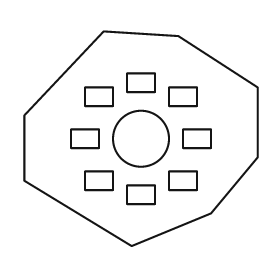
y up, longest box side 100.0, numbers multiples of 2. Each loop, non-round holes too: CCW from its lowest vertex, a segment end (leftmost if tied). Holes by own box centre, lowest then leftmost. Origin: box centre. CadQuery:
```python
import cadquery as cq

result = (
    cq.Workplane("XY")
    .moveTo(-4.0, -46.0)
    .lineTo(30.0, -32.0)
    .lineTo(50.0, -8.0)
    .lineTo(50.0, 22.0)
    .lineTo(16.0, 44.0)
    .lineTo(-16.0, 46.0)
    .lineTo(-50.0, 10.0)
    .lineTo(-50.0, -18.0)
    .close()
    .moveTo(-6.0, -28.0)
    .lineTo(6.0, -28.0)
    .lineTo(6.0, -20.0)
    .lineTo(-6.0, -20.0)
    .close()
    .moveTo(-24.0, -22.0)
    .lineTo(-12.0, -22.0)
    .lineTo(-12.0, -14.0)
    .lineTo(-24.0, -14.0)
    .close()
    .moveTo(12.0, -22.0)
    .lineTo(24.0, -22.0)
    .lineTo(24.0, -14.0)
    .lineTo(12.0, -14.0)
    .close()
    .moveTo(-30.0, -4.0)
    .lineTo(-18.0, -4.0)
    .lineTo(-18.0, 4.0)
    .lineTo(-30.0, 4.0)
    .close()
    .moveTo(0.0, 0.0)
    .circle(12.0)
    .moveTo(18.0, -4.0)
    .lineTo(30.0, -4.0)
    .lineTo(30.0, 4.0)
    .lineTo(18.0, 4.0)
    .close()
    .moveTo(-24.0, 14.0)
    .lineTo(-12.0, 14.0)
    .lineTo(-12.0, 22.0)
    .lineTo(-24.0, 22.0)
    .close()
    .moveTo(12.0, 14.0)
    .lineTo(24.0, 14.0)
    .lineTo(24.0, 22.0)
    .lineTo(12.0, 22.0)
    .close()
    .moveTo(-6.0, 20.0)
    .lineTo(6.0, 20.0)
    .lineTo(6.0, 28.0)
    .lineTo(-6.0, 28.0)
    .close()
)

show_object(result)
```